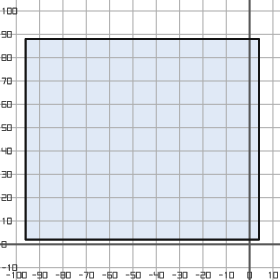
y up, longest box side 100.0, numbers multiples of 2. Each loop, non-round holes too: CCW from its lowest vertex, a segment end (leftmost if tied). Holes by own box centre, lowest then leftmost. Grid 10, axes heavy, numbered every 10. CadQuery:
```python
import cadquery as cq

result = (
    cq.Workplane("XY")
    .moveTo(-96.0, 2.0)
    .lineTo(4.0, 2.0)
    .lineTo(4.0, 88.0)
    .lineTo(-96.0, 88.0)
    .close()
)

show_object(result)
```